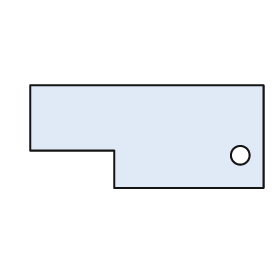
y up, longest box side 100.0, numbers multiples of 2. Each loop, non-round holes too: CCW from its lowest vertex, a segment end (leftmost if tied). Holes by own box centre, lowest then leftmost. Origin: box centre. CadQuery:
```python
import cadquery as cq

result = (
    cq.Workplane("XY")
    .moveTo(-14.0, -22.0)
    .lineTo(50.0, -22.0)
    .lineTo(50.0, 22.0)
    .lineTo(-50.0, 22.0)
    .lineTo(-50.0, -6.0)
    .lineTo(-14.0, -6.0)
    .close()
    .moveTo(40.0, -8.0)
    .circle(4.0)
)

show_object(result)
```